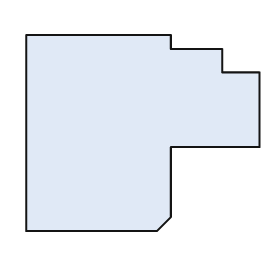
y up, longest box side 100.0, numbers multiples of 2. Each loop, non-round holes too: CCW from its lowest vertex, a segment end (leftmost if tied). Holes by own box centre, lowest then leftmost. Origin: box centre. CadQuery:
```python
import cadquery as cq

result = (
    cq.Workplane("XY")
    .moveTo(-50.0, -42.0)
    .lineTo(6.0, -42.0)
    .lineTo(12.0, -36.0)
    .lineTo(12.0, -6.0)
    .lineTo(50.0, -6.0)
    .lineTo(50.0, 26.0)
    .lineTo(34.0, 26.0)
    .lineTo(34.0, 36.0)
    .lineTo(12.0, 36.0)
    .lineTo(12.0, 42.0)
    .lineTo(-50.0, 42.0)
    .close()
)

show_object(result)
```